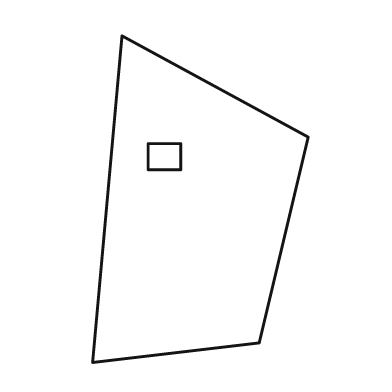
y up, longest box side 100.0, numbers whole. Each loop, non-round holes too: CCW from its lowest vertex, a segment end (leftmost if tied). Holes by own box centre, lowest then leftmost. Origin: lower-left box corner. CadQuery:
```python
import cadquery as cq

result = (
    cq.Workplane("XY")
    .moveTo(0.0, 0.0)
    .lineTo(51.0, 6.0)
    .lineTo(66.0, 69.0)
    .lineTo(9.0, 100.0)
    .close()
    .moveTo(17.0, 59.0)
    .lineTo(27.0, 59.0)
    .lineTo(27.0, 67.0)
    .lineTo(17.0, 67.0)
    .close()
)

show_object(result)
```